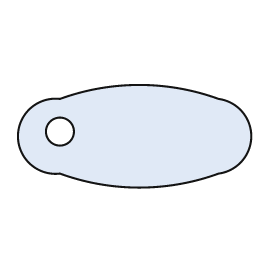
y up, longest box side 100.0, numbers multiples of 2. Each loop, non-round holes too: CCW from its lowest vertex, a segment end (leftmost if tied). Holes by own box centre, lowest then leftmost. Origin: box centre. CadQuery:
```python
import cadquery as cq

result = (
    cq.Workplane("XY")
    .moveTo(-32.0, -16.0)
    .threePointArc((2.0, -22.0), (36.0, -16.0))
    .threePointArc((50.0, 0.0), (36.0, 16.0))
    .threePointArc((2.0, 22.0), (-32.0, 16.0))
    .threePointArc((-50.0, 0.0), (-32.0, -16.0))
    .close()
    .moveTo(-32.0, 2.0)
    .circle(6.0)
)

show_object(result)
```